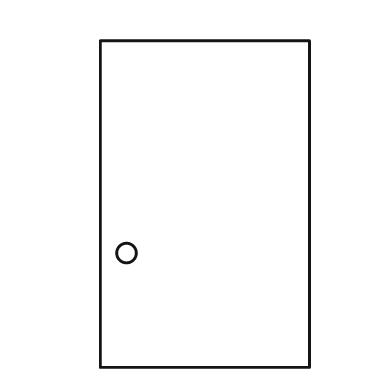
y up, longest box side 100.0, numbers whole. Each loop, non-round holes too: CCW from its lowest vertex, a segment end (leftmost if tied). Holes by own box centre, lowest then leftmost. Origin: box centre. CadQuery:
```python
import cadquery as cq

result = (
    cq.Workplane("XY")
    .moveTo(-32.0, -50.0)
    .lineTo(32.0, -50.0)
    .lineTo(32.0, 50.0)
    .lineTo(-32.0, 50.0)
    .close()
    .moveTo(-24.0, -15.0)
    .circle(3.0)
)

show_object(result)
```